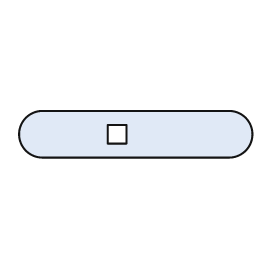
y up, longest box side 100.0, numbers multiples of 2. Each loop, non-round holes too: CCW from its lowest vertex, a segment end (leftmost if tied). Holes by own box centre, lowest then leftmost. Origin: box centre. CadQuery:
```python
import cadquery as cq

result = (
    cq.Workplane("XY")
    .moveTo(-40.0, -10.0)
    .lineTo(40.0, -10.0)
    .threePointArc((50.0, 0.0), (40.0, 10.0))
    .lineTo(-40.0, 10.0)
    .threePointArc((-50.0, 0.0), (-40.0, -10.0))
    .close()
    .moveTo(-12.0, -4.0)
    .lineTo(-4.0, -4.0)
    .lineTo(-4.0, 4.0)
    .lineTo(-12.0, 4.0)
    .close()
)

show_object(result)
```